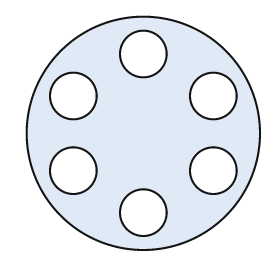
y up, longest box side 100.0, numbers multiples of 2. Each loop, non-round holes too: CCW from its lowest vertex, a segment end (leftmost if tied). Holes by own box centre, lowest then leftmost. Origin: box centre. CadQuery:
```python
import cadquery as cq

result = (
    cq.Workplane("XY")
    .moveTo(0.0, 0.0)
    .circle(50.0)
    .moveTo(0.0, -34.0)
    .circle(10.0)
    .moveTo(-30.0, -16.0)
    .circle(10.0)
    .moveTo(30.0, -16.0)
    .circle(10.0)
    .moveTo(-30.0, 16.0)
    .circle(10.0)
    .moveTo(30.0, 16.0)
    .circle(10.0)
    .moveTo(0.0, 34.0)
    .circle(10.0)
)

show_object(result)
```